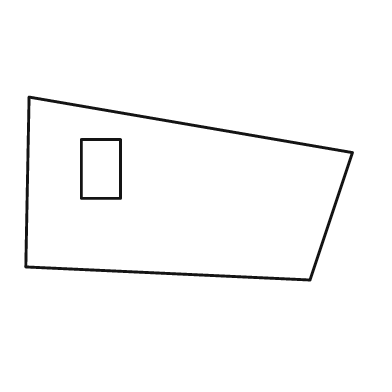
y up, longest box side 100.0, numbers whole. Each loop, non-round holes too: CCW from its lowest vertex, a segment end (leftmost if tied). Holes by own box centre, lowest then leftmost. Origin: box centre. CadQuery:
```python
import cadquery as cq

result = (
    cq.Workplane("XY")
    .moveTo(37.0, -28.0)
    .lineTo(50.0, 11.0)
    .lineTo(-49.0, 28.0)
    .lineTo(-50.0, -24.0)
    .close()
    .moveTo(-33.0, -3.0)
    .lineTo(-21.0, -3.0)
    .lineTo(-21.0, 15.0)
    .lineTo(-33.0, 15.0)
    .close()
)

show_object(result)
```